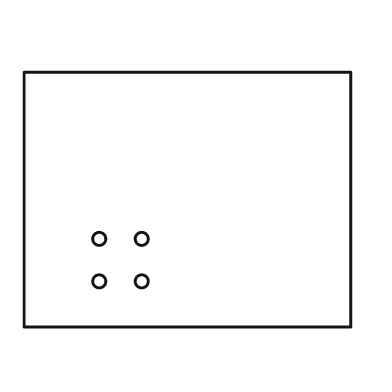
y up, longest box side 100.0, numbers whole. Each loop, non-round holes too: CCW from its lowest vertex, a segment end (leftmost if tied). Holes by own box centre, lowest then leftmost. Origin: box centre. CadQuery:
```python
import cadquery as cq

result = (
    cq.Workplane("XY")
    .moveTo(-50.0, -39.0)
    .lineTo(50.0, -39.0)
    .lineTo(50.0, 39.0)
    .lineTo(-50.0, 39.0)
    .close()
    .moveTo(-27.0, -25.0)
    .circle(2.0)
    .moveTo(-14.0, -25.0)
    .circle(2.0)
    .moveTo(-27.0, -12.0)
    .circle(2.0)
    .moveTo(-14.0, -12.0)
    .circle(2.0)
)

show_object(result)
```